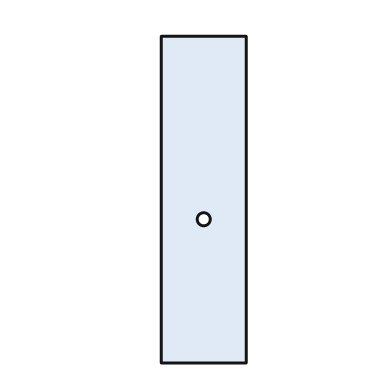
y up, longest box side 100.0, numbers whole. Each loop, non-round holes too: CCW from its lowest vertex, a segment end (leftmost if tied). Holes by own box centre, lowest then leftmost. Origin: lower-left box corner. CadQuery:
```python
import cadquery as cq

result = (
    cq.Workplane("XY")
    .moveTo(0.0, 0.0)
    .lineTo(26.0, 0.0)
    .lineTo(26.0, 100.0)
    .lineTo(0.0, 100.0)
    .close()
    .moveTo(13.0, 44.0)
    .circle(2.0)
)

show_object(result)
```